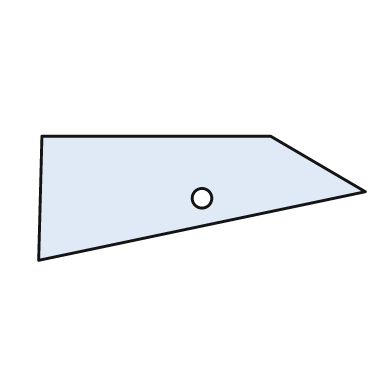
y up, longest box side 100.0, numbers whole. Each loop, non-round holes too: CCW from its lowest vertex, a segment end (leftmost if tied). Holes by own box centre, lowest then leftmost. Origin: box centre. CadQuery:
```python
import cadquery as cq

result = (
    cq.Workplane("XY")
    .moveTo(-50.0, -19.0)
    .lineTo(50.0, 2.0)
    .lineTo(21.0, 19.0)
    .lineTo(-49.0, 19.0)
    .close()
    .moveTo(0.0, 0.0)
    .circle(3.0)
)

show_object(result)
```